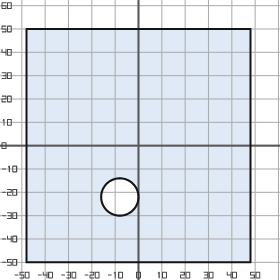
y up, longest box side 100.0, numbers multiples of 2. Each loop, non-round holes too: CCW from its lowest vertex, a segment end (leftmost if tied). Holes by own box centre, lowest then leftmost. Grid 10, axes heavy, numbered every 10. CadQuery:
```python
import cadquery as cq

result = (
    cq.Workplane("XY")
    .moveTo(-48.0, -50.0)
    .lineTo(48.0, -50.0)
    .lineTo(48.0, 50.0)
    .lineTo(-48.0, 50.0)
    .close()
    .moveTo(-8.0, -22.0)
    .circle(8.0)
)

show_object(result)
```